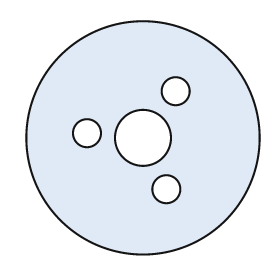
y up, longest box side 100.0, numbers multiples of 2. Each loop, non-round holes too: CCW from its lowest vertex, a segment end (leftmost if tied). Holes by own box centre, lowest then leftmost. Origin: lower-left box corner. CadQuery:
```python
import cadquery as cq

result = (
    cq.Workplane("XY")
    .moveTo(50.0, 50.0)
    .circle(50.0)
    .moveTo(60.0, 28.0)
    .circle(6.0)
    .moveTo(50.0, 50.0)
    .circle(12.0)
    .moveTo(26.0, 52.0)
    .circle(6.0)
    .moveTo(64.0, 70.0)
    .circle(6.0)
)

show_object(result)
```